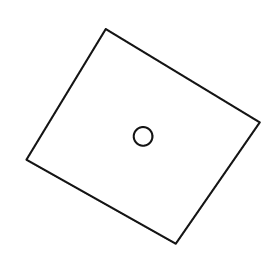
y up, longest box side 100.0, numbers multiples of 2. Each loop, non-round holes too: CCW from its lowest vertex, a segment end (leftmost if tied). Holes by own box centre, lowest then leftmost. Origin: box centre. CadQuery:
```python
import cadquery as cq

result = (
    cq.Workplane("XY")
    .moveTo(14.0, -46.0)
    .lineTo(50.0, 6.0)
    .lineTo(-16.0, 46.0)
    .lineTo(-50.0, -10.0)
    .close()
    .moveTo(0.0, 0.0)
    .circle(4.0)
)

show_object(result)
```